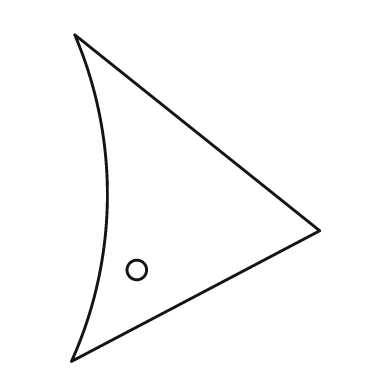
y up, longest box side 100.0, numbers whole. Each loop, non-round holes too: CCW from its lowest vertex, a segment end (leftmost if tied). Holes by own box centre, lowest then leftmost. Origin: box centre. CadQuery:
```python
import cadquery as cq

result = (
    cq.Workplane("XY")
    .moveTo(-38.0, -50.0)
    .lineTo(38.0, -10.0)
    .lineTo(-37.0, 50.0)
    .threePointArc((-27.0, 0.0), (-38.0, -50.0))
    .close()
    .moveTo(-18.0, -22.0)
    .circle(3.0)
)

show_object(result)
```